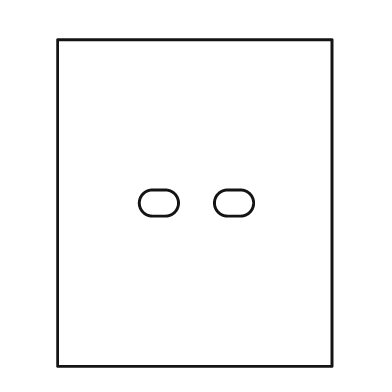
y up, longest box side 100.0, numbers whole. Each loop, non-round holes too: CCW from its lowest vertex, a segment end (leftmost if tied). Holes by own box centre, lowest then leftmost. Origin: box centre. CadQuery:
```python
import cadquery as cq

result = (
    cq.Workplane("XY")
    .moveTo(-42.0, -50.0)
    .lineTo(42.0, -50.0)
    .lineTo(42.0, 50.0)
    .lineTo(-42.0, 50.0)
    .close()
    .moveTo(-13.0, -4.0)
    .lineTo(-9.0, -4.0)
    .threePointArc((-5.0, 0.0), (-9.0, 4.0))
    .lineTo(-13.0, 4.0)
    .threePointArc((-17.0, 0.0), (-13.0, -4.0))
    .close()
    .moveTo(10.0, -4.0)
    .lineTo(14.0, -4.0)
    .threePointArc((18.0, 0.0), (14.0, 4.0))
    .lineTo(10.0, 4.0)
    .threePointArc((6.0, 0.0), (10.0, -4.0))
    .close()
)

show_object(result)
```